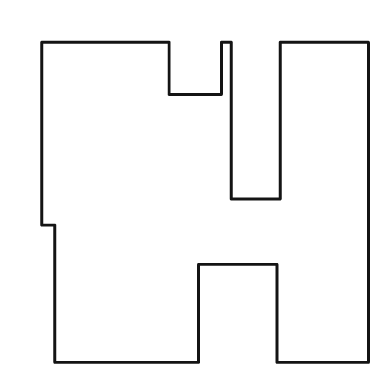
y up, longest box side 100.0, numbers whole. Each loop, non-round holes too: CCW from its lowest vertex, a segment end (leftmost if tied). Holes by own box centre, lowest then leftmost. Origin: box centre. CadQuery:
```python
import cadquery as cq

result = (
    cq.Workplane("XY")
    .moveTo(-46.0, -49.0)
    .lineTo(-2.0, -49.0)
    .lineTo(-2.0, -19.0)
    .lineTo(22.0, -19.0)
    .lineTo(22.0, -49.0)
    .lineTo(50.0, -49.0)
    .lineTo(50.0, 49.0)
    .lineTo(23.0, 49.0)
    .lineTo(23.0, 1.0)
    .lineTo(8.0, 1.0)
    .lineTo(8.0, 49.0)
    .lineTo(5.0, 49.0)
    .lineTo(5.0, 33.0)
    .lineTo(-11.0, 33.0)
    .lineTo(-11.0, 49.0)
    .lineTo(-50.0, 49.0)
    .lineTo(-50.0, -7.0)
    .lineTo(-46.0, -7.0)
    .close()
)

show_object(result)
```